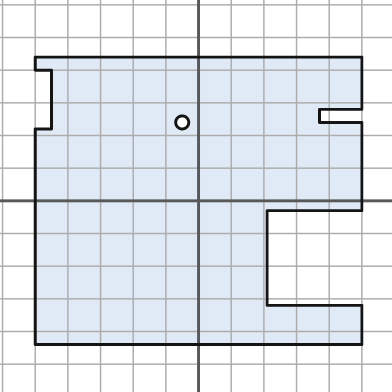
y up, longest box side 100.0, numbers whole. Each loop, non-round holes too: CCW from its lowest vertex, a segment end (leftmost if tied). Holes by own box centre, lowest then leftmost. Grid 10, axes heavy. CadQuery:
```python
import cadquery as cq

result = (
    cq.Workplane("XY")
    .moveTo(-50.0, -44.0)
    .lineTo(50.0, -44.0)
    .lineTo(50.0, -32.0)
    .lineTo(21.0, -32.0)
    .lineTo(21.0, -3.0)
    .lineTo(50.0, -3.0)
    .lineTo(50.0, 24.0)
    .lineTo(37.0, 24.0)
    .lineTo(37.0, 28.0)
    .lineTo(50.0, 28.0)
    .lineTo(50.0, 44.0)
    .lineTo(-50.0, 44.0)
    .lineTo(-50.0, 40.0)
    .lineTo(-45.0, 40.0)
    .lineTo(-45.0, 22.0)
    .lineTo(-50.0, 22.0)
    .close()
    .moveTo(-5.0, 24.0)
    .circle(2.0)
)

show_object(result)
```